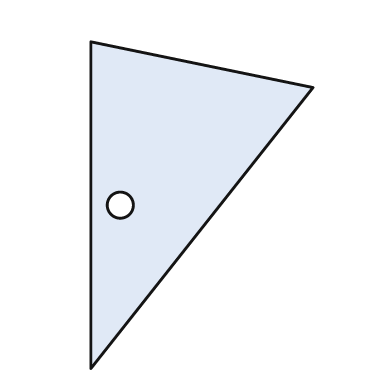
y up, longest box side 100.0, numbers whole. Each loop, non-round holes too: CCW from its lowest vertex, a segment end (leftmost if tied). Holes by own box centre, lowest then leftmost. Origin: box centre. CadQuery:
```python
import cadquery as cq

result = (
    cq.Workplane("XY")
    .moveTo(-34.0, -50.0)
    .lineTo(34.0, 36.0)
    .lineTo(-34.0, 50.0)
    .close()
    .moveTo(-25.0, 0.0)
    .circle(4.0)
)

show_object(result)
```